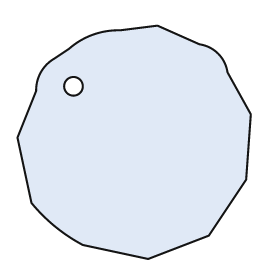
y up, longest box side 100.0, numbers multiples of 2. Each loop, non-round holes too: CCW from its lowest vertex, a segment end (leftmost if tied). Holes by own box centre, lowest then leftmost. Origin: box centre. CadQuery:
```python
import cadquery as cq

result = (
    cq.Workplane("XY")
    .moveTo(6.0, -50.0)
    .lineTo(32.0, -40.0)
    .lineTo(48.0, -16.0)
    .lineTo(50.0, 12.0)
    .lineTo(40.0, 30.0)
    .threePointArc((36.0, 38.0), (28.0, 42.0))
    .lineTo(10.0, 50.0)
    .lineTo(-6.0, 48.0)
    .threePointArc((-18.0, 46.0), (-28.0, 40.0))
    .lineTo(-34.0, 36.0)
    .threePointArc((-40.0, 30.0), (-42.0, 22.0))
    .lineTo(-50.0, 2.0)
    .lineTo(-44.0, -26.0)
    .threePointArc((-34.0, -36.0), (-22.0, -44.0))
    .close()
    .moveTo(-26.0, 24.0)
    .circle(4.0)
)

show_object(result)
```